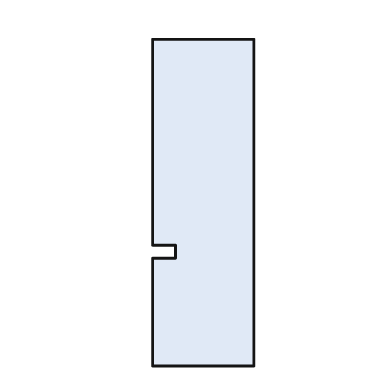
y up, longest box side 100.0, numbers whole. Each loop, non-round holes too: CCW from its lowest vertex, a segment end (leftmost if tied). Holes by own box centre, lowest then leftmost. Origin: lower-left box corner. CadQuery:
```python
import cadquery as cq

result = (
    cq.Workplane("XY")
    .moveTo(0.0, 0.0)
    .lineTo(31.0, 0.0)
    .lineTo(31.0, 100.0)
    .lineTo(0.0, 100.0)
    .lineTo(0.0, 37.0)
    .lineTo(7.0, 37.0)
    .lineTo(7.0, 33.0)
    .lineTo(0.0, 33.0)
    .close()
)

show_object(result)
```